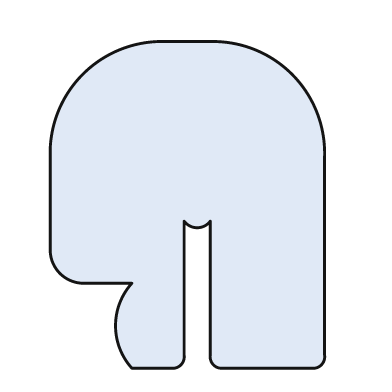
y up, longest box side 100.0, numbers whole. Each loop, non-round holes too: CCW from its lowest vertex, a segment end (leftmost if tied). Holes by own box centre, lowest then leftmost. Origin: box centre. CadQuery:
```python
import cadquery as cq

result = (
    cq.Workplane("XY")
    .moveTo(-17.0, -50.0)
    .lineTo(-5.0, -50.0)
    .threePointArc((-2.0, -49.0), (-1.0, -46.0))
    .lineTo(-1.0, -5.0)
    .threePointArc((3.0, -7.0), (7.0, -5.0))
    .lineTo(7.0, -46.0)
    .threePointArc((8.0, -49.0), (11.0, -50.0))
    .lineTo(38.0, -50.0)
    .threePointArc((41.0, -49.0), (42.0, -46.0))
    .lineTo(42.0, 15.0)
    .threePointArc((32.0, 40.0), (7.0, 50.0))
    .lineTo(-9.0, 50.0)
    .threePointArc((-32.0, 40.0), (-42.0, 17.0))
    .lineTo(-42.0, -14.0)
    .threePointArc((-39.0, -21.0), (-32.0, -24.0))
    .lineTo(-17.0, -24.0)
    .threePointArc((-22.0, -37.0), (-17.0, -50.0))
    .close()
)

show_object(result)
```